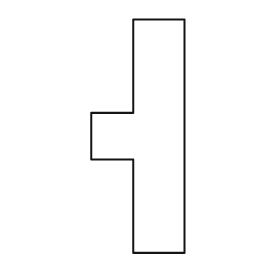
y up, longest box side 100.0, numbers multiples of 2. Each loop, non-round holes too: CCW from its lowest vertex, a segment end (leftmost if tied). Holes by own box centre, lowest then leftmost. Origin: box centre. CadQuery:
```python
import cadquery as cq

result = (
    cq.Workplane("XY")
    .moveTo(-2.0, -50.0)
    .lineTo(20.0, -50.0)
    .lineTo(20.0, 50.0)
    .lineTo(-2.0, 50.0)
    .lineTo(-2.0, 10.0)
    .lineTo(-20.0, 10.0)
    .lineTo(-20.0, -10.0)
    .lineTo(-2.0, -10.0)
    .close()
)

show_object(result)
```